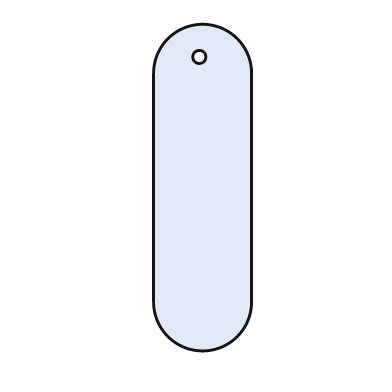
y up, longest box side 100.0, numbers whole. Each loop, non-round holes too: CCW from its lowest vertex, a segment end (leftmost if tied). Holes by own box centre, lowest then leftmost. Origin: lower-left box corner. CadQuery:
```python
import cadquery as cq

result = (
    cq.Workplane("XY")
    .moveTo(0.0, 15.0)
    .threePointArc((15.0, 0.0), (30.0, 15.0))
    .lineTo(30.0, 85.0)
    .threePointArc((15.0, 100.0), (0.0, 85.0))
    .close()
    .moveTo(14.0, 90.0)
    .circle(2.0)
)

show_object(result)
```